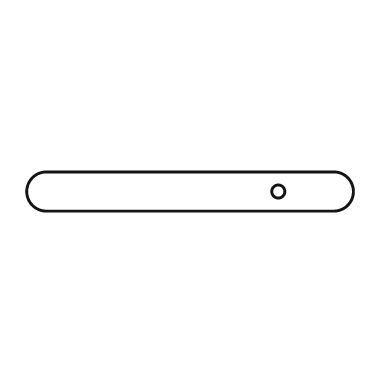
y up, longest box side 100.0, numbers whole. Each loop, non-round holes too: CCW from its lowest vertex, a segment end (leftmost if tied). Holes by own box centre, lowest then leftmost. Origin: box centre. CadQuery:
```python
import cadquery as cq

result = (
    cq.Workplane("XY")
    .moveTo(-44.0, -6.0)
    .lineTo(44.0, -6.0)
    .threePointArc((50.0, 0.0), (44.0, 6.0))
    .lineTo(-44.0, 6.0)
    .threePointArc((-50.0, 0.0), (-44.0, -6.0))
    .close()
    .moveTo(27.0, 0.0)
    .circle(2.0)
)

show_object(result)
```